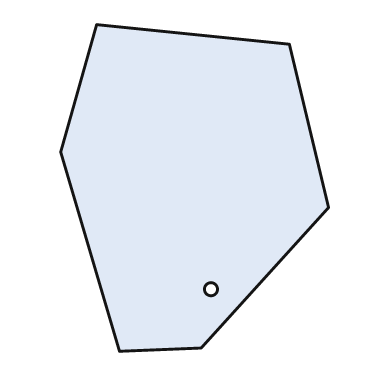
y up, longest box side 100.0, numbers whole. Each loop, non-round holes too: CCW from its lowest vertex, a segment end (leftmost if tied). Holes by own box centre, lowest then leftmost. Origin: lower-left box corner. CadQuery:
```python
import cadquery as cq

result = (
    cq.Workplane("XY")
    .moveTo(18.0, 0.0)
    .lineTo(43.0, 1.0)
    .lineTo(82.0, 44.0)
    .lineTo(70.0, 94.0)
    .lineTo(11.0, 100.0)
    .lineTo(0.0, 61.0)
    .close()
    .moveTo(46.0, 19.0)
    .circle(2.0)
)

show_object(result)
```